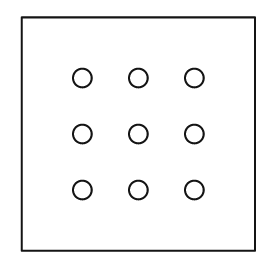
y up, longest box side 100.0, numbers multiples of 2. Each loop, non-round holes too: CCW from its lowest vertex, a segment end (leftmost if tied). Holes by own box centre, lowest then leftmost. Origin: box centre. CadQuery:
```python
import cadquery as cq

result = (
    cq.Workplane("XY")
    .moveTo(-50.0, -50.0)
    .lineTo(50.0, -50.0)
    .lineTo(50.0, 50.0)
    .lineTo(-50.0, 50.0)
    .close()
    .moveTo(-24.0, -24.0)
    .circle(4.0)
    .moveTo(0.0, -24.0)
    .circle(4.0)
    .moveTo(24.0, -24.0)
    .circle(4.0)
    .moveTo(-24.0, 0.0)
    .circle(4.0)
    .moveTo(0.0, 0.0)
    .circle(4.0)
    .moveTo(24.0, 0.0)
    .circle(4.0)
    .moveTo(-24.0, 24.0)
    .circle(4.0)
    .moveTo(0.0, 24.0)
    .circle(4.0)
    .moveTo(24.0, 24.0)
    .circle(4.0)
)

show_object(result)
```